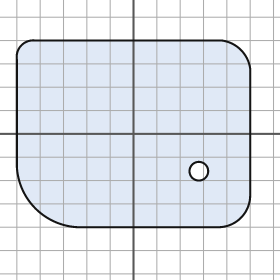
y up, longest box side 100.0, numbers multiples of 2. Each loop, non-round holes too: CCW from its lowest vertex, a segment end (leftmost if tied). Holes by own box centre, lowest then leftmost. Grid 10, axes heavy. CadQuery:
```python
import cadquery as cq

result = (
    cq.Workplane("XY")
    .moveTo(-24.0, -40.0)
    .lineTo(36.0, -40.0)
    .threePointArc((46.0, -36.0), (50.0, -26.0))
    .lineTo(50.0, 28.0)
    .threePointArc((46.0, 36.0), (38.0, 40.0))
    .lineTo(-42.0, 40.0)
    .threePointArc((-48.0, 38.0), (-50.0, 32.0))
    .lineTo(-50.0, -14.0)
    .threePointArc((-42.0, -32.0), (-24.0, -40.0))
    .close()
    .moveTo(28.0, -16.0)
    .circle(4.0)
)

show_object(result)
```